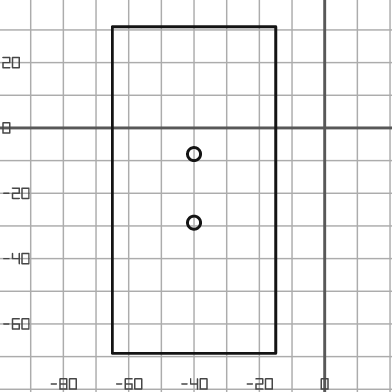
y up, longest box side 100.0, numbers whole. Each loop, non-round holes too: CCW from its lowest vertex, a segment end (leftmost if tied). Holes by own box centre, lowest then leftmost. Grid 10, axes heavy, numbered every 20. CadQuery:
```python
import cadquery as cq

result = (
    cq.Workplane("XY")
    .moveTo(-65.0, -69.0)
    .lineTo(-15.0, -69.0)
    .lineTo(-15.0, 31.0)
    .lineTo(-65.0, 31.0)
    .close()
    .moveTo(-40.0, -29.0)
    .circle(2.0)
    .moveTo(-40.0, -8.0)
    .circle(2.0)
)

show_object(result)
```